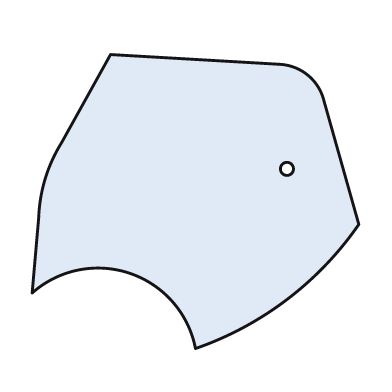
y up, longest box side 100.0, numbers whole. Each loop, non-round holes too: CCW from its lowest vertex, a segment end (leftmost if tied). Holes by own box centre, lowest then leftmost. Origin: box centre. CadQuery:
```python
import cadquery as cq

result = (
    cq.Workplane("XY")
    .moveTo(0.0, -45.0)
    .threePointArc((28.0, -30.0), (50.0, -7.0))
    .lineTo(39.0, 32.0)
    .threePointArc((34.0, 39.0), (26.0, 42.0))
    .lineTo(-26.0, 45.0)
    .lineTo(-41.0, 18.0)
    .threePointArc((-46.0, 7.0), (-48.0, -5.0))
    .lineTo(-50.0, -28.0)
    .threePointArc((-20.0, -22.0), (0.0, -45.0))
    .close()
    .moveTo(28.0, 10.0)
    .circle(2.0)
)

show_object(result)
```